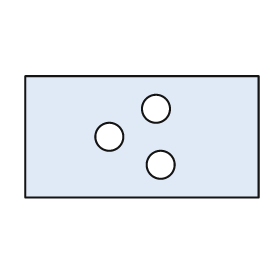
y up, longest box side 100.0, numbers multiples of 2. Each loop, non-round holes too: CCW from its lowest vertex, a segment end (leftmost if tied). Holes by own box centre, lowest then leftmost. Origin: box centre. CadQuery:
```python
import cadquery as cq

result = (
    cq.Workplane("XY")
    .moveTo(-50.0, -26.0)
    .lineTo(50.0, -26.0)
    .lineTo(50.0, 26.0)
    .lineTo(-50.0, 26.0)
    .close()
    .moveTo(8.0, -12.0)
    .circle(6.0)
    .moveTo(-14.0, 0.0)
    .circle(6.0)
    .moveTo(6.0, 12.0)
    .circle(6.0)
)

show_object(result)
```